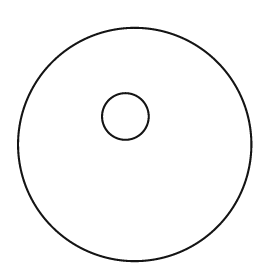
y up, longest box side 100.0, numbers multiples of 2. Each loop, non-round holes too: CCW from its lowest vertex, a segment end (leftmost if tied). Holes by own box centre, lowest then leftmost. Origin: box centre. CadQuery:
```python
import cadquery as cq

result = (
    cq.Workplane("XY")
    .moveTo(0.0, 0.0)
    .circle(50.0)
    .moveTo(-4.0, 12.0)
    .circle(10.0)
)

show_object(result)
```